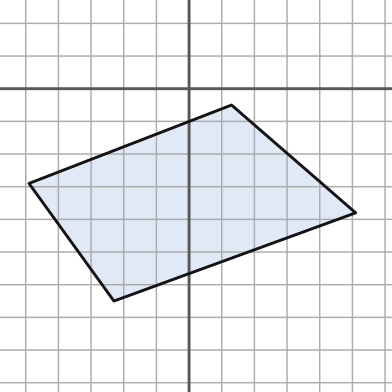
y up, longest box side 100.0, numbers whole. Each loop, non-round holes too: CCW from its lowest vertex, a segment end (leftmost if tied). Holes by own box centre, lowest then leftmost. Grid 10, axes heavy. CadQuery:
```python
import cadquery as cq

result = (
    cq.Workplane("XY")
    .moveTo(-23.0, -65.0)
    .lineTo(51.0, -38.0)
    .lineTo(13.0, -5.0)
    .lineTo(-49.0, -29.0)
    .close()
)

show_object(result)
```